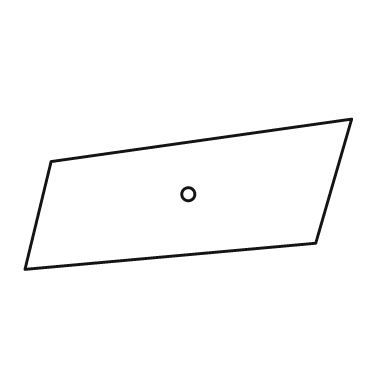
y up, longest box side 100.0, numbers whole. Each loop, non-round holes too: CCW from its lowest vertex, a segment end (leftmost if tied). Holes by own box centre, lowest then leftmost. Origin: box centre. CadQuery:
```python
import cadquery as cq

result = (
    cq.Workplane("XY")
    .moveTo(-50.0, -23.0)
    .lineTo(39.0, -15.0)
    .lineTo(50.0, 23.0)
    .lineTo(-42.0, 10.0)
    .close()
    .moveTo(0.0, 0.0)
    .circle(2.0)
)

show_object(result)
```